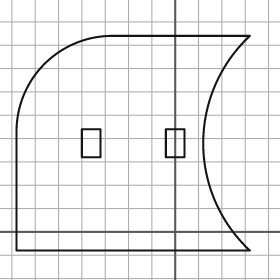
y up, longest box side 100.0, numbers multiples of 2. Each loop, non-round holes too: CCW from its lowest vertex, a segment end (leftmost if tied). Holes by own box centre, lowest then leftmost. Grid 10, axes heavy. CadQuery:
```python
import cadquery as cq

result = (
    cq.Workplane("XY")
    .moveTo(-68.0, -8.0)
    .lineTo(32.0, -8.0)
    .threePointArc((12.0, 38.0), (32.0, 84.0))
    .lineTo(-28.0, 84.0)
    .threePointArc((-56.0, 72.0), (-68.0, 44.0))
    .close()
    .moveTo(-40.0, 32.0)
    .lineTo(-32.0, 32.0)
    .lineTo(-32.0, 44.0)
    .lineTo(-40.0, 44.0)
    .close()
    .moveTo(-4.0, 32.0)
    .lineTo(4.0, 32.0)
    .lineTo(4.0, 44.0)
    .lineTo(-4.0, 44.0)
    .close()
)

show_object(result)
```